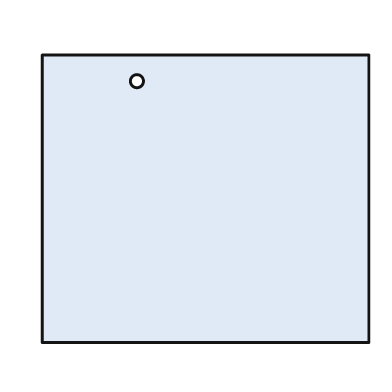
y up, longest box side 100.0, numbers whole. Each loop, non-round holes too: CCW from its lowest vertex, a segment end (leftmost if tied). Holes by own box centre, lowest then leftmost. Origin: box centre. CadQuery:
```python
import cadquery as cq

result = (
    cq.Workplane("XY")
    .moveTo(-50.0, -44.0)
    .lineTo(50.0, -44.0)
    .lineTo(50.0, 44.0)
    .lineTo(-50.0, 44.0)
    .close()
    .moveTo(-21.0, 36.0)
    .circle(2.0)
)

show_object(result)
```